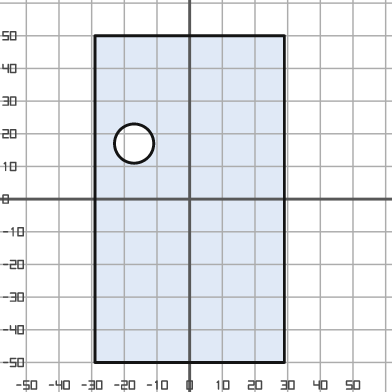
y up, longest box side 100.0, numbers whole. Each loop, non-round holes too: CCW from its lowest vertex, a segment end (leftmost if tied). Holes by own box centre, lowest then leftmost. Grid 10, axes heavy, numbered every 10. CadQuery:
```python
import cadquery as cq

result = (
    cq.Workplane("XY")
    .moveTo(-29.0, -50.0)
    .lineTo(29.0, -50.0)
    .lineTo(29.0, 50.0)
    .lineTo(-29.0, 50.0)
    .close()
    .moveTo(-17.0, 17.0)
    .circle(6.0)
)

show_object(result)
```